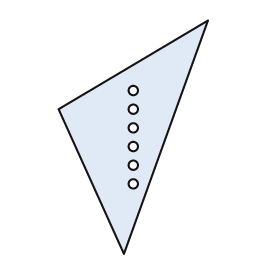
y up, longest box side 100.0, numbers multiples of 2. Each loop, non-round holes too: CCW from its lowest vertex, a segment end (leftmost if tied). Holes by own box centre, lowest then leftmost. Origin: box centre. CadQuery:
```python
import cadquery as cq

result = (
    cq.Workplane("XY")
    .moveTo(-4.0, -50.0)
    .lineTo(32.0, 50.0)
    .lineTo(-32.0, 12.0)
    .close()
    .moveTo(0.0, -20.0)
    .circle(2.0)
    .moveTo(0.0, -12.0)
    .circle(2.0)
    .moveTo(0.0, -4.0)
    .circle(2.0)
    .moveTo(0.0, 4.0)
    .circle(2.0)
    .moveTo(0.0, 12.0)
    .circle(2.0)
    .moveTo(0.0, 20.0)
    .circle(2.0)
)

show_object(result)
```